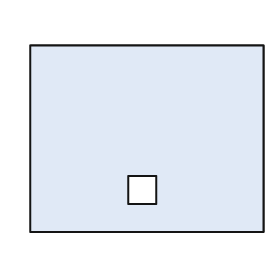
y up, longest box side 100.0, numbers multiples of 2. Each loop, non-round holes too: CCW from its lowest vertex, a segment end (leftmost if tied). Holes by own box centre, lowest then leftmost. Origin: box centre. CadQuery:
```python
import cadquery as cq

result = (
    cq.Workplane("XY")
    .moveTo(-50.0, -40.0)
    .lineTo(50.0, -40.0)
    .lineTo(50.0, 40.0)
    .lineTo(-50.0, 40.0)
    .close()
    .moveTo(-8.0, -28.0)
    .lineTo(4.0, -28.0)
    .lineTo(4.0, -16.0)
    .lineTo(-8.0, -16.0)
    .close()
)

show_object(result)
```